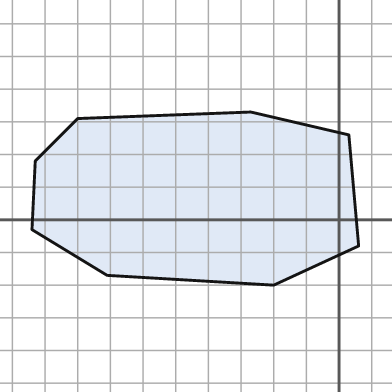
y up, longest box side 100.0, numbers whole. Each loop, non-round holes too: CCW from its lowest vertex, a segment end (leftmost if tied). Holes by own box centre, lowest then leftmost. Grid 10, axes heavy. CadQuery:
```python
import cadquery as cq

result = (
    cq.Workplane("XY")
    .moveTo(-20.0, -20.0)
    .lineTo(6.0, -8.0)
    .lineTo(3.0, 26.0)
    .lineTo(-27.0, 33.0)
    .lineTo(-80.0, 31.0)
    .lineTo(-93.0, 18.0)
    .lineTo(-94.0, -3.0)
    .lineTo(-71.0, -17.0)
    .close()
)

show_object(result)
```